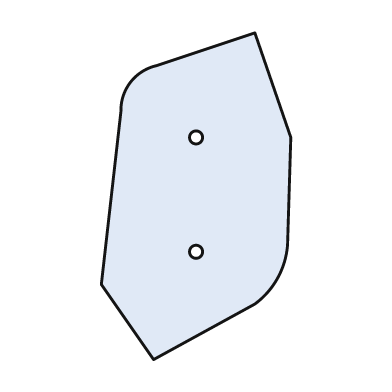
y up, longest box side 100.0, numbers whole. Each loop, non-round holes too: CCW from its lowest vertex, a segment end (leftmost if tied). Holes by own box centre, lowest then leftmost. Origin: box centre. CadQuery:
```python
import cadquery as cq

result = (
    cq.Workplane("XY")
    .moveTo(-13.0, -50.0)
    .lineTo(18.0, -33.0)
    .threePointArc((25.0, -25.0), (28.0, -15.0))
    .lineTo(29.0, 18.0)
    .lineTo(18.0, 50.0)
    .lineTo(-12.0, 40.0)
    .threePointArc((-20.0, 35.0), (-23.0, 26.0))
    .lineTo(-29.0, -27.0)
    .close()
    .moveTo(0.0, -17.0)
    .circle(2.0)
    .moveTo(0.0, 18.0)
    .circle(2.0)
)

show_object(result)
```